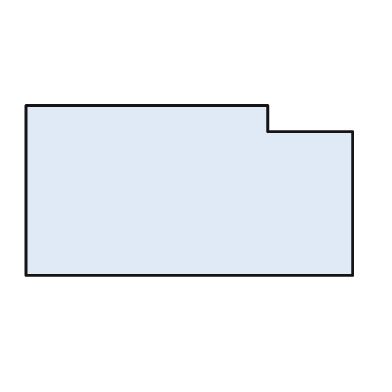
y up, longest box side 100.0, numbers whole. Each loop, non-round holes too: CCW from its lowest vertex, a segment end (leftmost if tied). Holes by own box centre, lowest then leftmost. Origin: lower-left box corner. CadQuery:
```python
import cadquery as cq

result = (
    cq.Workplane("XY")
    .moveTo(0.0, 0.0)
    .lineTo(100.0, 0.0)
    .lineTo(100.0, 44.0)
    .lineTo(74.0, 44.0)
    .lineTo(74.0, 52.0)
    .lineTo(0.0, 52.0)
    .close()
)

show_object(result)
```